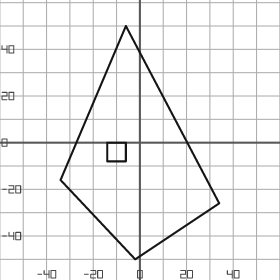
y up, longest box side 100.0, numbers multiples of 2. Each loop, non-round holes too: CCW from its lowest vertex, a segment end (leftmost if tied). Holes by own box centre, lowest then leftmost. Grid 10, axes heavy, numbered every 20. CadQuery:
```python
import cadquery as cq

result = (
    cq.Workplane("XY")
    .moveTo(-2.0, -50.0)
    .lineTo(34.0, -26.0)
    .lineTo(-6.0, 50.0)
    .lineTo(-34.0, -16.0)
    .close()
    .moveTo(-14.0, -8.0)
    .lineTo(-6.0, -8.0)
    .lineTo(-6.0, 0.0)
    .lineTo(-14.0, 0.0)
    .close()
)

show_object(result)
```